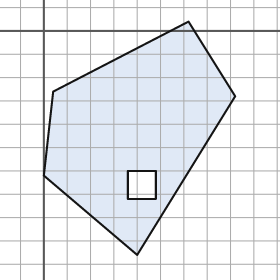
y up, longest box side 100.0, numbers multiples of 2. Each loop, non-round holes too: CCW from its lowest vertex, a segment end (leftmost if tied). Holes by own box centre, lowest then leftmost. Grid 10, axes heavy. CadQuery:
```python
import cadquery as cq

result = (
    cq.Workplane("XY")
    .moveTo(40.0, -96.0)
    .lineTo(82.0, -28.0)
    .lineTo(62.0, 4.0)
    .lineTo(4.0, -26.0)
    .lineTo(0.0, -62.0)
    .close()
    .moveTo(36.0, -72.0)
    .lineTo(48.0, -72.0)
    .lineTo(48.0, -60.0)
    .lineTo(36.0, -60.0)
    .close()
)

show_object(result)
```